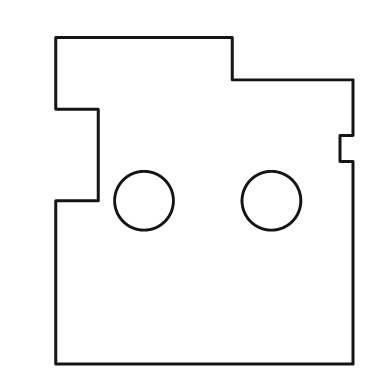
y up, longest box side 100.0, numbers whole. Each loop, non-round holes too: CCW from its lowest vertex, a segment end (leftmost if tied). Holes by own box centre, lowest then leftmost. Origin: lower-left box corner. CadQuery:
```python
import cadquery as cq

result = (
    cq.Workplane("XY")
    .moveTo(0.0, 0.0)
    .lineTo(91.0, 0.0)
    .lineTo(91.0, 62.0)
    .lineTo(87.0, 62.0)
    .lineTo(87.0, 70.0)
    .lineTo(91.0, 70.0)
    .lineTo(91.0, 87.0)
    .lineTo(54.0, 87.0)
    .lineTo(54.0, 100.0)
    .lineTo(0.0, 100.0)
    .lineTo(0.0, 78.0)
    .lineTo(13.0, 78.0)
    .lineTo(13.0, 50.0)
    .lineTo(0.0, 50.0)
    .close()
    .moveTo(27.0, 50.0)
    .circle(9.0)
    .moveTo(66.0, 50.0)
    .circle(9.0)
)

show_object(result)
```